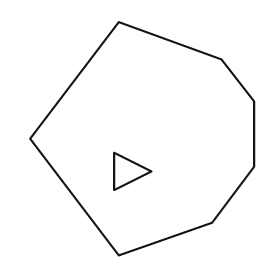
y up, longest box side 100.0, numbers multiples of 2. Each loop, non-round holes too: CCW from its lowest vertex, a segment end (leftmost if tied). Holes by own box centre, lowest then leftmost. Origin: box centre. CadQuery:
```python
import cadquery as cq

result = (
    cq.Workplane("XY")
    .moveTo(-10.0, -50.0)
    .lineTo(30.0, -36.0)
    .lineTo(48.0, -12.0)
    .lineTo(48.0, 16.0)
    .lineTo(34.0, 34.0)
    .lineTo(-10.0, 50.0)
    .lineTo(-48.0, 0.0)
    .close()
    .moveTo(-12.0, -22.0)
    .lineTo(4.0, -14.0)
    .lineTo(-12.0, -6.0)
    .close()
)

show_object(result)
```